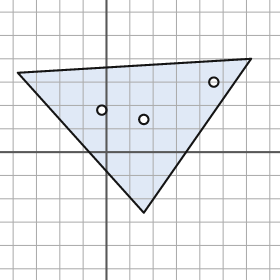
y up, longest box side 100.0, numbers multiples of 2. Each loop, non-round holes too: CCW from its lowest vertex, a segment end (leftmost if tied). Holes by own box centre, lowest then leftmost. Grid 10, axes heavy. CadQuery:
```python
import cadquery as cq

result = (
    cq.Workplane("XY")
    .moveTo(16.0, -26.0)
    .lineTo(62.0, 40.0)
    .lineTo(-38.0, 34.0)
    .close()
    .moveTo(16.0, 14.0)
    .circle(2.0)
    .moveTo(-2.0, 18.0)
    .circle(2.0)
    .moveTo(46.0, 30.0)
    .circle(2.0)
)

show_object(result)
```